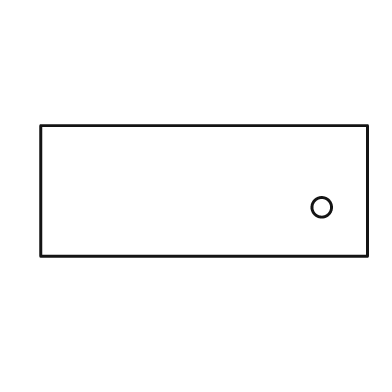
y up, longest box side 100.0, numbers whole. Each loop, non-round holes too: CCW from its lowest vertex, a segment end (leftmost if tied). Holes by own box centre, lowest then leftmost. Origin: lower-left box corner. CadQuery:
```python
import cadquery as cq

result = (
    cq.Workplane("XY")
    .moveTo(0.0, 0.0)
    .lineTo(100.0, 0.0)
    .lineTo(100.0, 40.0)
    .lineTo(0.0, 40.0)
    .close()
    .moveTo(86.0, 15.0)
    .circle(3.0)
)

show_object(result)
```